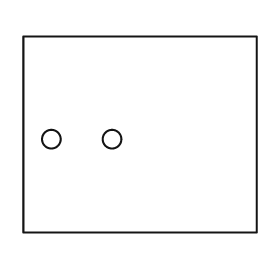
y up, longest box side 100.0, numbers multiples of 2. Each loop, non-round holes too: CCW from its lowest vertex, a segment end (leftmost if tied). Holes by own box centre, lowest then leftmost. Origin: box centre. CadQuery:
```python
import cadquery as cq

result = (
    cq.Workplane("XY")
    .moveTo(-50.0, -42.0)
    .lineTo(50.0, -42.0)
    .lineTo(50.0, 42.0)
    .lineTo(-50.0, 42.0)
    .close()
    .moveTo(-38.0, -2.0)
    .circle(4.0)
    .moveTo(-12.0, -2.0)
    .circle(4.0)
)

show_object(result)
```